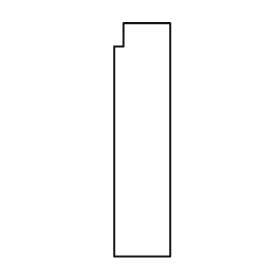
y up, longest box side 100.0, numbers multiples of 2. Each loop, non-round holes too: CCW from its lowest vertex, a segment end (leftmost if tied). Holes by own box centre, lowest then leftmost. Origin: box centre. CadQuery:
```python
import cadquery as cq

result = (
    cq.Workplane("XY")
    .moveTo(-12.0, -50.0)
    .lineTo(12.0, -50.0)
    .lineTo(12.0, 50.0)
    .lineTo(-8.0, 50.0)
    .lineTo(-8.0, 40.0)
    .lineTo(-12.0, 40.0)
    .close()
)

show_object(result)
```